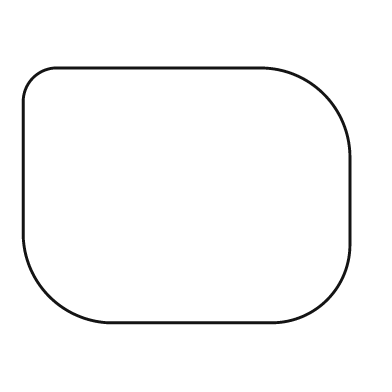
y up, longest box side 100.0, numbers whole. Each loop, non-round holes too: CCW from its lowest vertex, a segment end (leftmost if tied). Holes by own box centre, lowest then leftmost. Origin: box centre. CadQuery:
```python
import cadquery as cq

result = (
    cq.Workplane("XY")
    .moveTo(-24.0, -39.0)
    .lineTo(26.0, -39.0)
    .threePointArc((43.0, -32.0), (50.0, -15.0))
    .lineTo(50.0, 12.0)
    .threePointArc((42.0, 31.0), (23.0, 39.0))
    .lineTo(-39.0, 39.0)
    .threePointArc((-47.0, 36.0), (-50.0, 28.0))
    .lineTo(-50.0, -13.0)
    .threePointArc((-42.0, -31.0), (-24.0, -39.0))
    .close()
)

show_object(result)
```